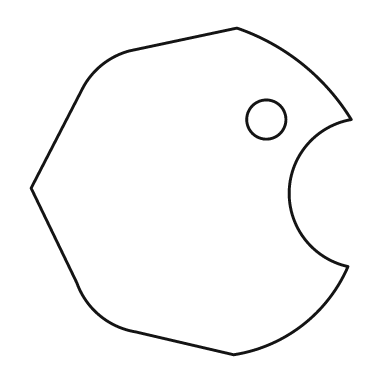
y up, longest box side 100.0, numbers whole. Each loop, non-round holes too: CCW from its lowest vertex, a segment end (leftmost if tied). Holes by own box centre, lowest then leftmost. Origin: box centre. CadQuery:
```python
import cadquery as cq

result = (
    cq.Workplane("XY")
    .moveTo(13.0, -50.0)
    .threePointArc((34.0, -41.0), (48.0, -23.0))
    .threePointArc((30.0, 0.0), (49.0, 22.0))
    .threePointArc((34.0, 39.0), (14.0, 50.0))
    .lineTo(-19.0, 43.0)
    .threePointArc((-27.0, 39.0), (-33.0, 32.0))
    .lineTo(-49.0, 1.0)
    .lineTo(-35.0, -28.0)
    .threePointArc((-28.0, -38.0), (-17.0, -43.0))
    .close()
    .moveTo(23.0, 22.0)
    .circle(6.0)
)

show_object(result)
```